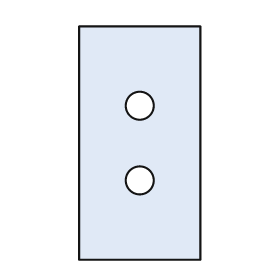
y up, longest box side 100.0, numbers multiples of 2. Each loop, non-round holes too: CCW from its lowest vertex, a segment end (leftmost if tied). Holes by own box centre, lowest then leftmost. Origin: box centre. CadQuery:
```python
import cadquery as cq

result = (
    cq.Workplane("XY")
    .moveTo(-26.0, -50.0)
    .lineTo(26.0, -50.0)
    .lineTo(26.0, 50.0)
    .lineTo(-26.0, 50.0)
    .close()
    .moveTo(0.0, -16.0)
    .circle(6.0)
    .moveTo(0.0, 16.0)
    .circle(6.0)
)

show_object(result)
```